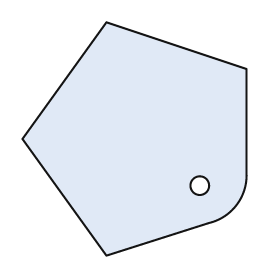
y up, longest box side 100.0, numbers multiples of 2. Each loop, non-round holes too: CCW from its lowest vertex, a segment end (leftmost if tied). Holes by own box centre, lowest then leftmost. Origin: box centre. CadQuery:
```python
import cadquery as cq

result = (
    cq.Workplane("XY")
    .moveTo(-12.0, -50.0)
    .lineTo(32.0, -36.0)
    .threePointArc((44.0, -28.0), (48.0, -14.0))
    .lineTo(48.0, 30.0)
    .lineTo(-12.0, 50.0)
    .lineTo(-48.0, 0.0)
    .close()
    .moveTo(28.0, -20.0)
    .circle(4.0)
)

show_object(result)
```